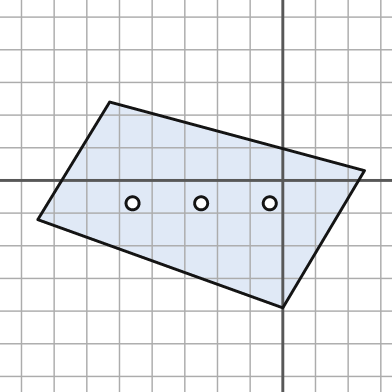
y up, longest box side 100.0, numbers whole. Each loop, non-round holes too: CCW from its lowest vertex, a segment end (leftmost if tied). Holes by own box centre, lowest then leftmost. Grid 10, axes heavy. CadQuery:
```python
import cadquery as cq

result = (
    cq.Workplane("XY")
    .moveTo(0.0, -39.0)
    .lineTo(25.0, 3.0)
    .lineTo(-53.0, 24.0)
    .lineTo(-75.0, -12.0)
    .close()
    .moveTo(-46.0, -7.0)
    .circle(2.0)
    .moveTo(-25.0, -7.0)
    .circle(2.0)
    .moveTo(-4.0, -7.0)
    .circle(2.0)
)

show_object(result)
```